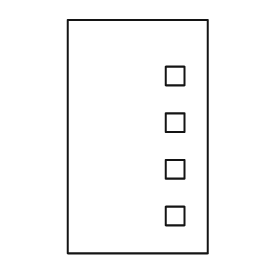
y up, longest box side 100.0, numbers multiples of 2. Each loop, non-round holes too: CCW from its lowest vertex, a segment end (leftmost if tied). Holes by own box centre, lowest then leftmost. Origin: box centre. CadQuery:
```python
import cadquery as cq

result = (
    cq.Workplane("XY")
    .moveTo(-30.0, -50.0)
    .lineTo(30.0, -50.0)
    .lineTo(30.0, 50.0)
    .lineTo(-30.0, 50.0)
    .close()
    .moveTo(12.0, -38.0)
    .lineTo(20.0, -38.0)
    .lineTo(20.0, -30.0)
    .lineTo(12.0, -30.0)
    .close()
    .moveTo(12.0, -18.0)
    .lineTo(20.0, -18.0)
    .lineTo(20.0, -10.0)
    .lineTo(12.0, -10.0)
    .close()
    .moveTo(12.0, 2.0)
    .lineTo(20.0, 2.0)
    .lineTo(20.0, 10.0)
    .lineTo(12.0, 10.0)
    .close()
    .moveTo(12.0, 22.0)
    .lineTo(20.0, 22.0)
    .lineTo(20.0, 30.0)
    .lineTo(12.0, 30.0)
    .close()
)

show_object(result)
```